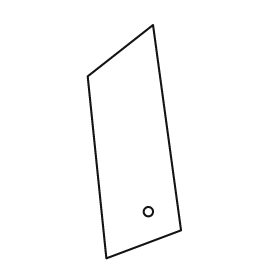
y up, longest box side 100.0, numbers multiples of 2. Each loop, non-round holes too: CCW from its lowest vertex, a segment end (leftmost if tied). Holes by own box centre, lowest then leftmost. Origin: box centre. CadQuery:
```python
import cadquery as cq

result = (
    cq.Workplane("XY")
    .moveTo(-12.0, -50.0)
    .lineTo(20.0, -38.0)
    .lineTo(8.0, 50.0)
    .lineTo(-20.0, 28.0)
    .close()
    .moveTo(6.0, -30.0)
    .circle(2.0)
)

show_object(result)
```